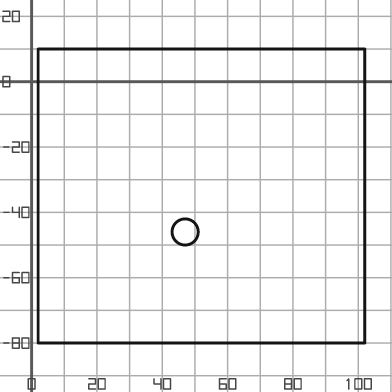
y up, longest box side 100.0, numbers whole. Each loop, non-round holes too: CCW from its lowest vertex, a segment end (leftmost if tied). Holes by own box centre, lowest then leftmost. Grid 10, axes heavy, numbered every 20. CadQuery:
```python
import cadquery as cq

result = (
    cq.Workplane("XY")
    .moveTo(2.0, -80.0)
    .lineTo(102.0, -80.0)
    .lineTo(102.0, 10.0)
    .lineTo(2.0, 10.0)
    .close()
    .moveTo(47.0, -46.0)
    .circle(4.0)
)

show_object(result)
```